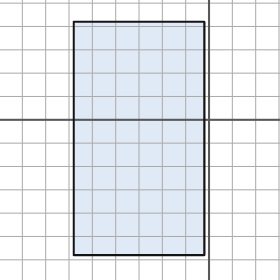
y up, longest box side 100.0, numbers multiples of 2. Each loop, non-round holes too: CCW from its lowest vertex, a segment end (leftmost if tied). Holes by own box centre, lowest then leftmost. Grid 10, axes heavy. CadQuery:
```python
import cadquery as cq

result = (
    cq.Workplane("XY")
    .moveTo(-58.0, -58.0)
    .lineTo(-2.0, -58.0)
    .lineTo(-2.0, 42.0)
    .lineTo(-58.0, 42.0)
    .close()
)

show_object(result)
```